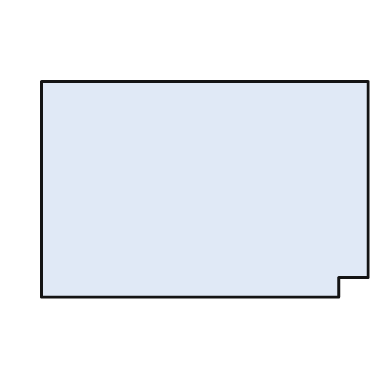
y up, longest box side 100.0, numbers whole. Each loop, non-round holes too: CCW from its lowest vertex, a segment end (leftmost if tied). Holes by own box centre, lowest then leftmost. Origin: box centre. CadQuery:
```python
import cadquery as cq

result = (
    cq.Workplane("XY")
    .moveTo(-50.0, -33.0)
    .lineTo(41.0, -33.0)
    .lineTo(41.0, -27.0)
    .lineTo(50.0, -27.0)
    .lineTo(50.0, 33.0)
    .lineTo(-50.0, 33.0)
    .close()
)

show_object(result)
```